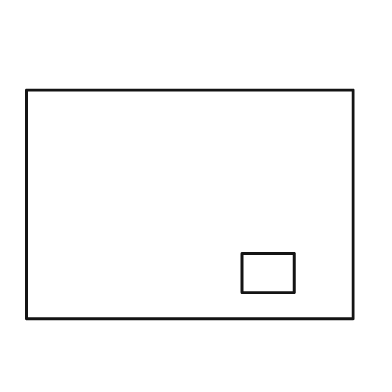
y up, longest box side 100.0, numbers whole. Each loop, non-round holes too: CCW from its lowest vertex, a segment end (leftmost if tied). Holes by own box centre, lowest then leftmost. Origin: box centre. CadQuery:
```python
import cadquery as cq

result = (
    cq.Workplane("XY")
    .moveTo(-50.0, -35.0)
    .lineTo(50.0, -35.0)
    .lineTo(50.0, 35.0)
    .lineTo(-50.0, 35.0)
    .close()
    .moveTo(16.0, -27.0)
    .lineTo(32.0, -27.0)
    .lineTo(32.0, -15.0)
    .lineTo(16.0, -15.0)
    .close()
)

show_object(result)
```